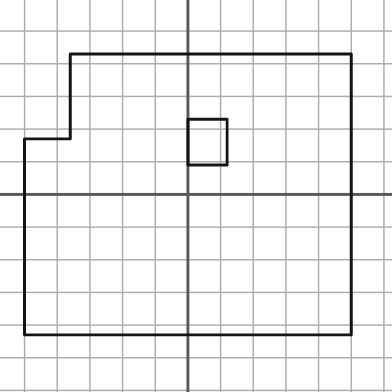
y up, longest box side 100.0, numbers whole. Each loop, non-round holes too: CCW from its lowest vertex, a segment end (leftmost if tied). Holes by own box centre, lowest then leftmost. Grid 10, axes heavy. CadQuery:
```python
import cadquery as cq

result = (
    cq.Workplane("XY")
    .moveTo(-50.0, -43.0)
    .lineTo(50.0, -43.0)
    .lineTo(50.0, 43.0)
    .lineTo(-36.0, 43.0)
    .lineTo(-36.0, 17.0)
    .lineTo(-50.0, 17.0)
    .close()
    .moveTo(0.0, 9.0)
    .lineTo(12.0, 9.0)
    .lineTo(12.0, 23.0)
    .lineTo(0.0, 23.0)
    .close()
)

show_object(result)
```